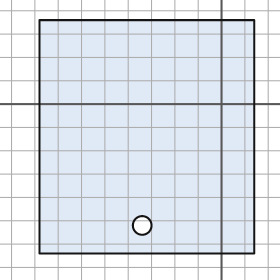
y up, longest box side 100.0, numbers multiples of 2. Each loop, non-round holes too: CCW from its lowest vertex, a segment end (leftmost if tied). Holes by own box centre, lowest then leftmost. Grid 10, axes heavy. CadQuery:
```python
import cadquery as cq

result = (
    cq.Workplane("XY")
    .moveTo(-78.0, -64.0)
    .lineTo(14.0, -64.0)
    .lineTo(14.0, 36.0)
    .lineTo(-78.0, 36.0)
    .close()
    .moveTo(-34.0, -52.0)
    .circle(4.0)
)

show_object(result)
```